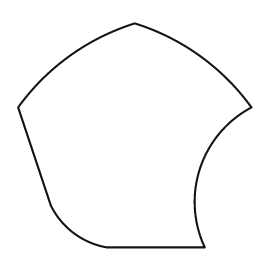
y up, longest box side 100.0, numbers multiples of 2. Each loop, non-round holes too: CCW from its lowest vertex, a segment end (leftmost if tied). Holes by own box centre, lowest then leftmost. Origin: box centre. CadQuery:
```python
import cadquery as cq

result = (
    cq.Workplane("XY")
    .moveTo(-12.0, -48.0)
    .lineTo(30.0, -48.0)
    .threePointArc((28.0, -14.0), (50.0, 12.0))
    .threePointArc((28.0, 34.0), (0.0, 48.0))
    .threePointArc((-28.0, 34.0), (-50.0, 12.0))
    .lineTo(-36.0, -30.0)
    .threePointArc((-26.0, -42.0), (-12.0, -48.0))
    .close()
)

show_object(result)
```